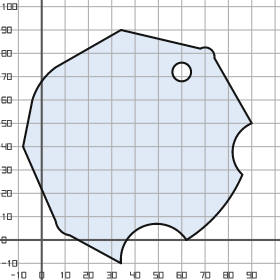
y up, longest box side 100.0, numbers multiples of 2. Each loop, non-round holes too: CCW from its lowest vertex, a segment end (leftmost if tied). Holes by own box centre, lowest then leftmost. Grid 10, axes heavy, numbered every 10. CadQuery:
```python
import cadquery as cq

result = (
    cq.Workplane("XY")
    .moveTo(34.0, -10.0)
    .threePointArc((44.0, 6.0), (62.0, 0.0))
    .threePointArc((76.0, 12.0), (86.0, 28.0))
    .threePointArc((82.0, 40.0), (90.0, 50.0))
    .lineTo(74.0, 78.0)
    .threePointArc((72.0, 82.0), (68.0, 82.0))
    .lineTo(34.0, 90.0)
    .lineTo(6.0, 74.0)
    .threePointArc((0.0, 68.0), (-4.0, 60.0))
    .lineTo(-8.0, 40.0)
    .lineTo(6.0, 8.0)
    .threePointArc((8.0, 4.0), (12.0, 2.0))
    .close()
    .moveTo(60.0, 72.0)
    .circle(4.0)
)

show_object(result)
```